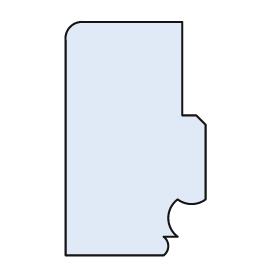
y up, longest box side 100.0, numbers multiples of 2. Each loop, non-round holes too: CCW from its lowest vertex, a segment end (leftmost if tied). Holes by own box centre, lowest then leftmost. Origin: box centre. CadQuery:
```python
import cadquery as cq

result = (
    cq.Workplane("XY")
    .moveTo(-30.0, -50.0)
    .lineTo(12.0, -50.0)
    .threePointArc((14.0, -46.0), (12.0, -42.0))
    .lineTo(18.0, -42.0)
    .threePointArc((14.0, -34.0), (18.0, -26.0))
    .threePointArc((24.0, -28.0), (30.0, -26.0))
    .lineTo(30.0, 6.0)
    .lineTo(26.0, 10.0)
    .lineTo(20.0, 10.0)
    .lineTo(20.0, 50.0)
    .lineTo(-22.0, 50.0)
    .threePointArc((-28.0, 48.0), (-30.0, 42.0))
    .close()
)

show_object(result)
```